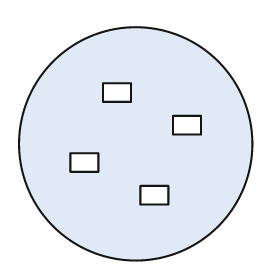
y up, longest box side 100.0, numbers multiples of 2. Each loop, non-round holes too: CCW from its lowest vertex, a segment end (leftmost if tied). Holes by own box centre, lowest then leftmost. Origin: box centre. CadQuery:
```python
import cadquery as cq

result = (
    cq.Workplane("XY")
    .moveTo(0.0, 0.0)
    .circle(50.0)
    .moveTo(2.0, -26.0)
    .lineTo(14.0, -26.0)
    .lineTo(14.0, -18.0)
    .lineTo(2.0, -18.0)
    .close()
    .moveTo(-28.0, -12.0)
    .lineTo(-16.0, -12.0)
    .lineTo(-16.0, -4.0)
    .lineTo(-28.0, -4.0)
    .close()
    .moveTo(16.0, 4.0)
    .lineTo(28.0, 4.0)
    .lineTo(28.0, 12.0)
    .lineTo(16.0, 12.0)
    .close()
    .moveTo(-14.0, 18.0)
    .lineTo(-2.0, 18.0)
    .lineTo(-2.0, 26.0)
    .lineTo(-14.0, 26.0)
    .close()
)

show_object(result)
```